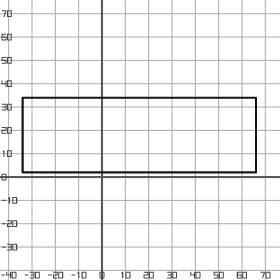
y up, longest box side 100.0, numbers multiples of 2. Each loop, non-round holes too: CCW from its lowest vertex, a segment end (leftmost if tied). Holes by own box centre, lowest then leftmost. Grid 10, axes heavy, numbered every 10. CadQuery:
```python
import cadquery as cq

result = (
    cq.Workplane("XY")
    .moveTo(-34.0, 2.0)
    .lineTo(66.0, 2.0)
    .lineTo(66.0, 34.0)
    .lineTo(-34.0, 34.0)
    .close()
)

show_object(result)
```